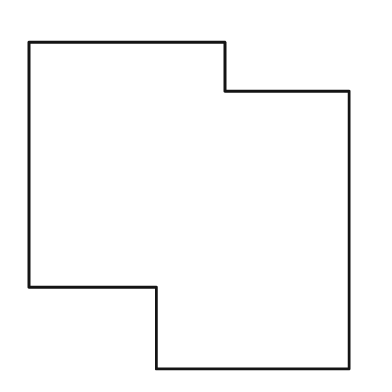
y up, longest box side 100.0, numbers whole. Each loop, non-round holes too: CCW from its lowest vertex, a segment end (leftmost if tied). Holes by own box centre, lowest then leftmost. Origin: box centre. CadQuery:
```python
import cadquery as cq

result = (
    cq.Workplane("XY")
    .moveTo(-10.0, -50.0)
    .lineTo(49.0, -50.0)
    .lineTo(49.0, 35.0)
    .lineTo(11.0, 35.0)
    .lineTo(11.0, 50.0)
    .lineTo(-49.0, 50.0)
    .lineTo(-49.0, -25.0)
    .lineTo(-10.0, -25.0)
    .close()
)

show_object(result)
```